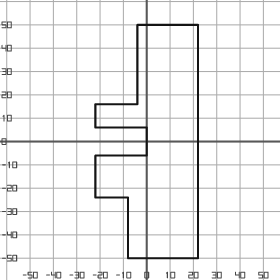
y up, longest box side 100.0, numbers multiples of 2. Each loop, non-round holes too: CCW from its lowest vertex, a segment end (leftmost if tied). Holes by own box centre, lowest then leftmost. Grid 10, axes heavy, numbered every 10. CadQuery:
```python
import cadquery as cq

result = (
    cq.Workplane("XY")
    .moveTo(-8.0, -50.0)
    .lineTo(22.0, -50.0)
    .lineTo(22.0, 50.0)
    .lineTo(-4.0, 50.0)
    .lineTo(-4.0, 16.0)
    .lineTo(-22.0, 16.0)
    .lineTo(-22.0, 6.0)
    .lineTo(0.0, 6.0)
    .lineTo(0.0, -6.0)
    .lineTo(-22.0, -6.0)
    .lineTo(-22.0, -24.0)
    .lineTo(-8.0, -24.0)
    .close()
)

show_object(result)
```